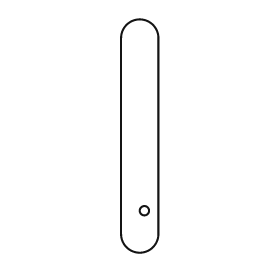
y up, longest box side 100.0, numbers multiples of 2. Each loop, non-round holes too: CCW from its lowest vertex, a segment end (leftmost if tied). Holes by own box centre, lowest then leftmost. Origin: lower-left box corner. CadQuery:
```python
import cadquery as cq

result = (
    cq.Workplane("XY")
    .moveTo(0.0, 8.0)
    .threePointArc((8.0, 0.0), (16.0, 8.0))
    .lineTo(16.0, 92.0)
    .threePointArc((8.0, 100.0), (0.0, 92.0))
    .close()
    .moveTo(10.0, 18.0)
    .circle(2.0)
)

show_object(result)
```